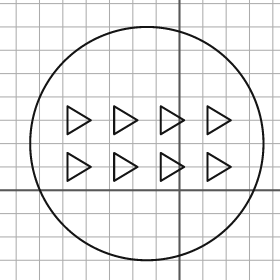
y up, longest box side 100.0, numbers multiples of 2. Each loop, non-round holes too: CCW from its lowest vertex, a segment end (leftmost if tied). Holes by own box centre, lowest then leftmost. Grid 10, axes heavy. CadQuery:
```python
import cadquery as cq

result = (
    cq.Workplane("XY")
    .moveTo(-14.0, 20.0)
    .circle(50.0)
    .moveTo(-48.0, 4.0)
    .lineTo(-38.0, 10.0)
    .lineTo(-48.0, 16.0)
    .close()
    .moveTo(-28.0, 4.0)
    .lineTo(-18.0, 10.0)
    .lineTo(-28.0, 16.0)
    .close()
    .moveTo(-8.0, 4.0)
    .lineTo(2.0, 10.0)
    .lineTo(-8.0, 16.0)
    .close()
    .moveTo(12.0, 4.0)
    .lineTo(22.0, 10.0)
    .lineTo(12.0, 16.0)
    .close()
    .moveTo(-48.0, 24.0)
    .lineTo(-38.0, 30.0)
    .lineTo(-48.0, 36.0)
    .close()
    .moveTo(-28.0, 24.0)
    .lineTo(-18.0, 30.0)
    .lineTo(-28.0, 36.0)
    .close()
    .moveTo(-8.0, 24.0)
    .lineTo(2.0, 30.0)
    .lineTo(-8.0, 36.0)
    .close()
    .moveTo(12.0, 24.0)
    .lineTo(22.0, 30.0)
    .lineTo(12.0, 36.0)
    .close()
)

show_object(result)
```